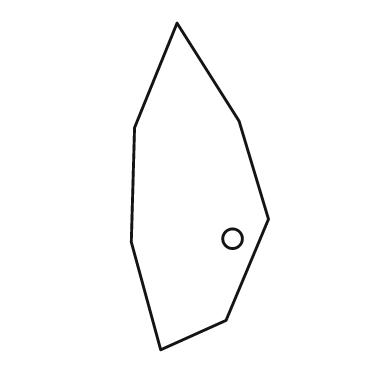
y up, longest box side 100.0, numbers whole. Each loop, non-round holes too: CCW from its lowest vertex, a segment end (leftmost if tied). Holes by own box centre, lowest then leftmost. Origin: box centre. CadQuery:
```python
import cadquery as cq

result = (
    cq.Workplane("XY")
    .moveTo(-12.0, -50.0)
    .lineTo(8.0, -41.0)
    .lineTo(21.0, -10.0)
    .lineTo(12.0, 20.0)
    .lineTo(-7.0, 50.0)
    .lineTo(-20.0, 18.0)
    .lineTo(-21.0, -17.0)
    .close()
    .moveTo(10.0, -16.0)
    .circle(3.0)
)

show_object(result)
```